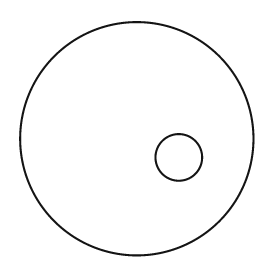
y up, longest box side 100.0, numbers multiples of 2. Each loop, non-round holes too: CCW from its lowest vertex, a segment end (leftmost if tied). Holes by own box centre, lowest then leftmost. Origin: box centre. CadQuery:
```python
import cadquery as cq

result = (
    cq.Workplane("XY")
    .moveTo(0.0, 0.0)
    .circle(50.0)
    .moveTo(18.0, -8.0)
    .circle(10.0)
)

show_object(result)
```